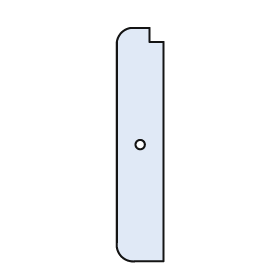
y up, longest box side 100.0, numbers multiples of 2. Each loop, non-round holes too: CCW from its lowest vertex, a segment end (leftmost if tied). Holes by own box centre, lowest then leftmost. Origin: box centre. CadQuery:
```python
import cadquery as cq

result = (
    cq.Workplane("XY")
    .moveTo(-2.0, -50.0)
    .lineTo(10.0, -50.0)
    .lineTo(10.0, 44.0)
    .lineTo(4.0, 44.0)
    .lineTo(4.0, 50.0)
    .lineTo(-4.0, 50.0)
    .threePointArc((-8.0, 48.0), (-10.0, 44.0))
    .lineTo(-10.0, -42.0)
    .threePointArc((-8.0, -48.0), (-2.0, -50.0))
    .close()
    .moveTo(0.0, 0.0)
    .circle(2.0)
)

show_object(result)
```